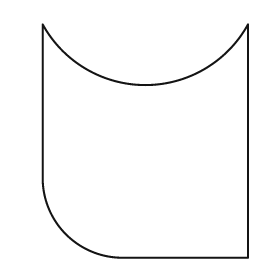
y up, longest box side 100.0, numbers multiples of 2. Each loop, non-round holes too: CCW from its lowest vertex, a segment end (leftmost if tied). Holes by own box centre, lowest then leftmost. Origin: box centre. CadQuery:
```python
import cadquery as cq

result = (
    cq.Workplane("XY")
    .moveTo(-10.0, -50.0)
    .lineTo(44.0, -50.0)
    .lineTo(44.0, 50.0)
    .threePointArc((0.0, 24.0), (-44.0, 50.0))
    .lineTo(-44.0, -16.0)
    .threePointArc((-34.0, -40.0), (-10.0, -50.0))
    .close()
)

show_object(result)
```